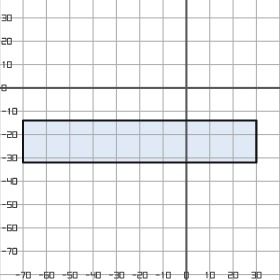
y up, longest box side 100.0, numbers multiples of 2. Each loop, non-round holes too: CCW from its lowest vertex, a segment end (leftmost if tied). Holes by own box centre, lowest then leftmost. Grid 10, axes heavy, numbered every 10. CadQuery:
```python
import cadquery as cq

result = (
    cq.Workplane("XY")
    .moveTo(-70.0, -32.0)
    .lineTo(30.0, -32.0)
    .lineTo(30.0, -14.0)
    .lineTo(-70.0, -14.0)
    .close()
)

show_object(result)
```